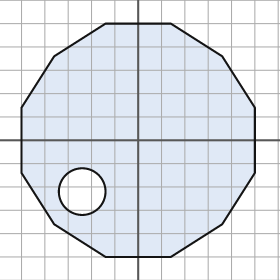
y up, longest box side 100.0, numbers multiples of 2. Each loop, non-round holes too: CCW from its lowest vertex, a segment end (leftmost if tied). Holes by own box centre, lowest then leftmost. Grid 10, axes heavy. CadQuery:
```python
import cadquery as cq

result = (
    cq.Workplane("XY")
    .moveTo(-14.0, -50.0)
    .lineTo(14.0, -50.0)
    .lineTo(36.0, -36.0)
    .lineTo(50.0, -14.0)
    .lineTo(50.0, 14.0)
    .lineTo(36.0, 36.0)
    .lineTo(14.0, 50.0)
    .lineTo(-14.0, 50.0)
    .lineTo(-36.0, 36.0)
    .lineTo(-50.0, 14.0)
    .lineTo(-50.0, -14.0)
    .lineTo(-36.0, -36.0)
    .close()
    .moveTo(-24.0, -22.0)
    .circle(10.0)
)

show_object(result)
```